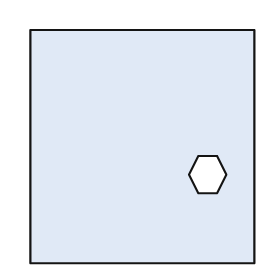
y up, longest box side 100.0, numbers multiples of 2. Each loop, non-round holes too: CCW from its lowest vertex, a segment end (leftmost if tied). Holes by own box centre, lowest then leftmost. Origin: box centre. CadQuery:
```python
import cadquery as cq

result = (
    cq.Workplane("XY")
    .moveTo(-48.0, -50.0)
    .lineTo(48.0, -50.0)
    .lineTo(48.0, 50.0)
    .lineTo(-48.0, 50.0)
    .close()
    .moveTo(24.0, -20.0)
    .lineTo(32.0, -20.0)
    .lineTo(36.0, -12.0)
    .lineTo(32.0, -4.0)
    .lineTo(24.0, -4.0)
    .lineTo(20.0, -12.0)
    .close()
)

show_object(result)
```